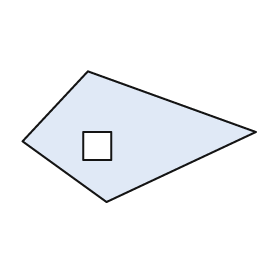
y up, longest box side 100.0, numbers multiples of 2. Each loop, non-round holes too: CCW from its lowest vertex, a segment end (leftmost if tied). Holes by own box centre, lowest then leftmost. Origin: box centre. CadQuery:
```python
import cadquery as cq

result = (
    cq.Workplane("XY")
    .moveTo(-14.0, -28.0)
    .lineTo(50.0, 2.0)
    .lineTo(-22.0, 28.0)
    .lineTo(-50.0, -2.0)
    .close()
    .moveTo(-24.0, -10.0)
    .lineTo(-12.0, -10.0)
    .lineTo(-12.0, 2.0)
    .lineTo(-24.0, 2.0)
    .close()
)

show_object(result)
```